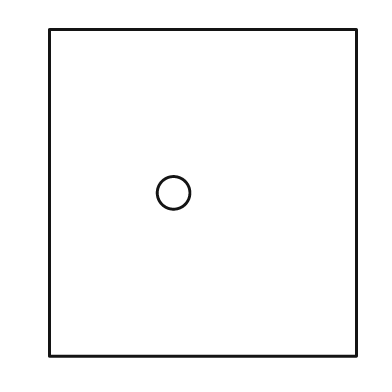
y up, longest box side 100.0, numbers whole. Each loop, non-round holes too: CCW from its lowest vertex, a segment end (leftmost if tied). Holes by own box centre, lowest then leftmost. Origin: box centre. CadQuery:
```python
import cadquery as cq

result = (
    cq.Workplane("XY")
    .moveTo(-47.0, -50.0)
    .lineTo(47.0, -50.0)
    .lineTo(47.0, 50.0)
    .lineTo(-47.0, 50.0)
    .close()
    .moveTo(-9.0, 0.0)
    .circle(5.0)
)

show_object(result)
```